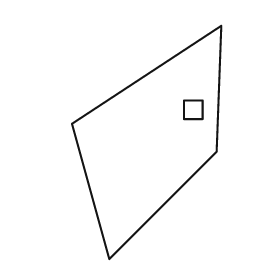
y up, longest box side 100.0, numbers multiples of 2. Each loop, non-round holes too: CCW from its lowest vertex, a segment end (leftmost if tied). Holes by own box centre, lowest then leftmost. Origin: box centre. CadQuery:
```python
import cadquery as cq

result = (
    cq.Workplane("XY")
    .moveTo(-16.0, -50.0)
    .lineTo(30.0, -4.0)
    .lineTo(32.0, 50.0)
    .lineTo(-32.0, 8.0)
    .close()
    .moveTo(16.0, 10.0)
    .lineTo(24.0, 10.0)
    .lineTo(24.0, 18.0)
    .lineTo(16.0, 18.0)
    .close()
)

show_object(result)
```